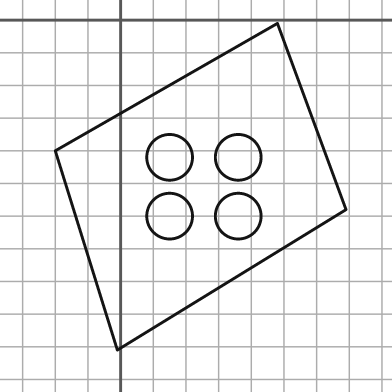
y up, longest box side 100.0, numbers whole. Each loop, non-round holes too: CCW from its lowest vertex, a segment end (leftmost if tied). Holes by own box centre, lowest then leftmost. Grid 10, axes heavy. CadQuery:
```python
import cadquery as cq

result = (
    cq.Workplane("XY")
    .moveTo(-1.0, -101.0)
    .lineTo(69.0, -58.0)
    .lineTo(48.0, -1.0)
    .lineTo(-20.0, -40.0)
    .close()
    .moveTo(15.0, -60.0)
    .circle(7.0)
    .moveTo(36.0, -60.0)
    .circle(7.0)
    .moveTo(15.0, -42.0)
    .circle(7.0)
    .moveTo(36.0, -42.0)
    .circle(7.0)
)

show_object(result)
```